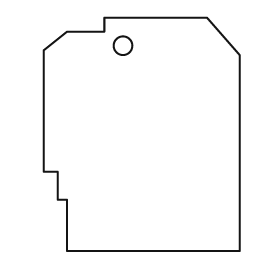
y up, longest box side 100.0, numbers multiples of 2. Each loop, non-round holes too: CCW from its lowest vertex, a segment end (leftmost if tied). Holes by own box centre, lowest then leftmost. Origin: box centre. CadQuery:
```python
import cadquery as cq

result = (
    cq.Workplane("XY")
    .moveTo(-32.0, -50.0)
    .lineTo(42.0, -50.0)
    .lineTo(42.0, 34.0)
    .lineTo(28.0, 50.0)
    .lineTo(-16.0, 50.0)
    .lineTo(-16.0, 44.0)
    .lineTo(-32.0, 44.0)
    .lineTo(-42.0, 36.0)
    .lineTo(-42.0, -16.0)
    .lineTo(-36.0, -16.0)
    .lineTo(-36.0, -28.0)
    .lineTo(-32.0, -28.0)
    .close()
    .moveTo(-8.0, 38.0)
    .circle(4.0)
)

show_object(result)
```